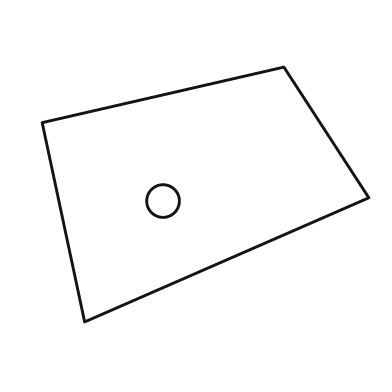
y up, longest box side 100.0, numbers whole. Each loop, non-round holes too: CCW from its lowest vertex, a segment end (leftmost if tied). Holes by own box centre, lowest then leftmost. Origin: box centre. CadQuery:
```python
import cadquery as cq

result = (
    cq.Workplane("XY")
    .moveTo(-37.0, -39.0)
    .lineTo(50.0, -1.0)
    .lineTo(24.0, 39.0)
    .lineTo(-50.0, 22.0)
    .close()
    .moveTo(-13.0, -2.0)
    .circle(5.0)
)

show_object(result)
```